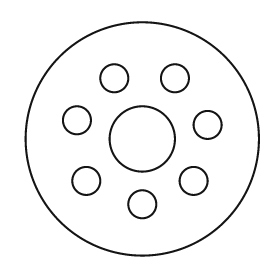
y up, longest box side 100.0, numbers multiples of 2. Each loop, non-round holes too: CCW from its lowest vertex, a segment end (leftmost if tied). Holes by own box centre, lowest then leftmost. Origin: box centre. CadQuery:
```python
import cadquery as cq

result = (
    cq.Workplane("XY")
    .moveTo(0.0, 0.0)
    .circle(50.0)
    .moveTo(0.0, -28.0)
    .circle(6.0)
    .moveTo(-24.0, -18.0)
    .circle(6.0)
    .moveTo(22.0, -18.0)
    .circle(6.0)
    .moveTo(0.0, 0.0)
    .circle(14.0)
    .moveTo(28.0, 6.0)
    .circle(6.0)
    .moveTo(-28.0, 8.0)
    .circle(6.0)
    .moveTo(-12.0, 26.0)
    .circle(6.0)
    .moveTo(14.0, 26.0)
    .circle(6.0)
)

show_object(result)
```